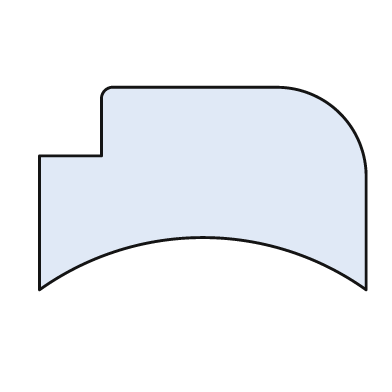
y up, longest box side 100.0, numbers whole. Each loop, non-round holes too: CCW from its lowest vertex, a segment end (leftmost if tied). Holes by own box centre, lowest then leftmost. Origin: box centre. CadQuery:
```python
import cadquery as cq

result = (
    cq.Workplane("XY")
    .moveTo(-50.0, -31.0)
    .threePointArc((0.0, -15.0), (50.0, -31.0))
    .lineTo(50.0, 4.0)
    .threePointArc((42.0, 23.0), (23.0, 31.0))
    .lineTo(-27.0, 31.0)
    .threePointArc((-30.0, 30.0), (-31.0, 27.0))
    .lineTo(-31.0, 10.0)
    .lineTo(-50.0, 10.0)
    .close()
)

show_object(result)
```